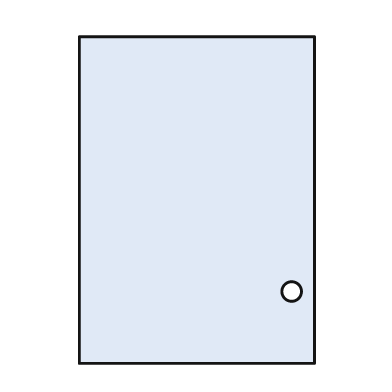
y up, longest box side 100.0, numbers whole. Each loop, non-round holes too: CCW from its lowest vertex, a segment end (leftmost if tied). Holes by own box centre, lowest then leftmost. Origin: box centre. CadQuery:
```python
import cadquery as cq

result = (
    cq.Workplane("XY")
    .moveTo(-36.0, -50.0)
    .lineTo(36.0, -50.0)
    .lineTo(36.0, 50.0)
    .lineTo(-36.0, 50.0)
    .close()
    .moveTo(29.0, -28.0)
    .circle(3.0)
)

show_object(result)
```